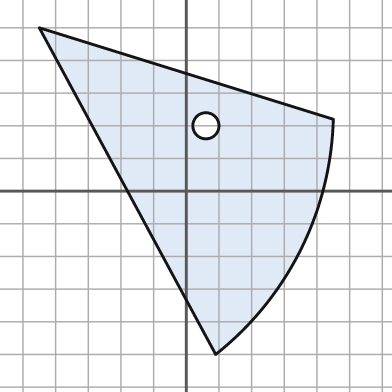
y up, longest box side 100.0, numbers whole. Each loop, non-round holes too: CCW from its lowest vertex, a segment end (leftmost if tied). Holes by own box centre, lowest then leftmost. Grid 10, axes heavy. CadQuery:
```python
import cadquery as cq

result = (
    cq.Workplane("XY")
    .moveTo(9.0, -50.0)
    .threePointArc((35.0, -18.0), (45.0, 22.0))
    .lineTo(-45.0, 50.0)
    .close()
    .moveTo(6.0, 20.0)
    .circle(4.0)
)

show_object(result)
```